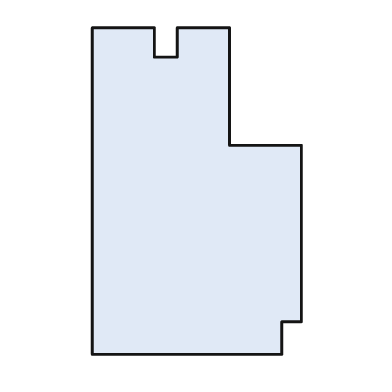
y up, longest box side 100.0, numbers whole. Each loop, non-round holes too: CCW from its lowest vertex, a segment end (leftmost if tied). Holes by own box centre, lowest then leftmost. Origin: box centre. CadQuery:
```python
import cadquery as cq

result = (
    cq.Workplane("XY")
    .moveTo(-32.0, -50.0)
    .lineTo(26.0, -50.0)
    .lineTo(26.0, -40.0)
    .lineTo(32.0, -40.0)
    .lineTo(32.0, 14.0)
    .lineTo(10.0, 14.0)
    .lineTo(10.0, 50.0)
    .lineTo(-6.0, 50.0)
    .lineTo(-6.0, 41.0)
    .lineTo(-13.0, 41.0)
    .lineTo(-13.0, 50.0)
    .lineTo(-32.0, 50.0)
    .close()
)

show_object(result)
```